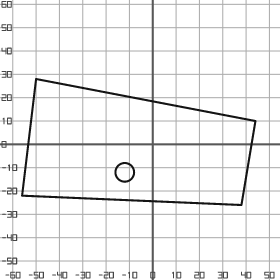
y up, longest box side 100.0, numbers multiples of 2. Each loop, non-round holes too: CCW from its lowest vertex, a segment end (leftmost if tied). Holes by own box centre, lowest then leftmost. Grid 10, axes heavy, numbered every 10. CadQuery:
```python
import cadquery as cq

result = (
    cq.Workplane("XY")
    .moveTo(38.0, -26.0)
    .lineTo(44.0, 10.0)
    .lineTo(-50.0, 28.0)
    .lineTo(-56.0, -22.0)
    .close()
    .moveTo(-12.0, -12.0)
    .circle(4.0)
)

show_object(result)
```